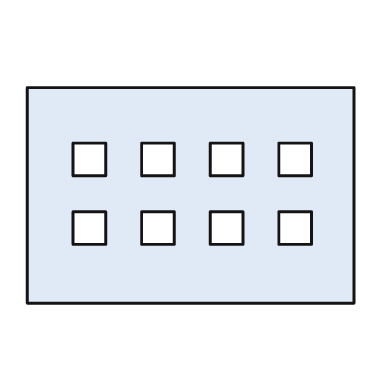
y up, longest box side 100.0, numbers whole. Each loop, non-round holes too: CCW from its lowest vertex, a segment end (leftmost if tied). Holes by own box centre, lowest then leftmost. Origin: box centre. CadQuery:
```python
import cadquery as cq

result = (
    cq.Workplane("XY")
    .moveTo(-50.0, -33.0)
    .lineTo(50.0, -33.0)
    .lineTo(50.0, 33.0)
    .lineTo(-50.0, 33.0)
    .close()
    .moveTo(-36.0, -15.0)
    .lineTo(-26.0, -15.0)
    .lineTo(-26.0, -5.0)
    .lineTo(-36.0, -5.0)
    .close()
    .moveTo(-15.0, -15.0)
    .lineTo(-5.0, -15.0)
    .lineTo(-5.0, -5.0)
    .lineTo(-15.0, -5.0)
    .close()
    .moveTo(6.0, -15.0)
    .lineTo(16.0, -15.0)
    .lineTo(16.0, -5.0)
    .lineTo(6.0, -5.0)
    .close()
    .moveTo(27.0, -15.0)
    .lineTo(37.0, -15.0)
    .lineTo(37.0, -5.0)
    .lineTo(27.0, -5.0)
    .close()
    .moveTo(-36.0, 6.0)
    .lineTo(-26.0, 6.0)
    .lineTo(-26.0, 16.0)
    .lineTo(-36.0, 16.0)
    .close()
    .moveTo(-15.0, 6.0)
    .lineTo(-5.0, 6.0)
    .lineTo(-5.0, 16.0)
    .lineTo(-15.0, 16.0)
    .close()
    .moveTo(6.0, 6.0)
    .lineTo(16.0, 6.0)
    .lineTo(16.0, 16.0)
    .lineTo(6.0, 16.0)
    .close()
    .moveTo(27.0, 6.0)
    .lineTo(37.0, 6.0)
    .lineTo(37.0, 16.0)
    .lineTo(27.0, 16.0)
    .close()
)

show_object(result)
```